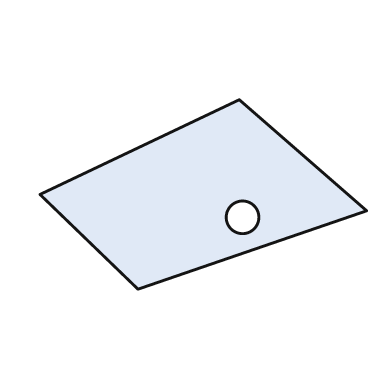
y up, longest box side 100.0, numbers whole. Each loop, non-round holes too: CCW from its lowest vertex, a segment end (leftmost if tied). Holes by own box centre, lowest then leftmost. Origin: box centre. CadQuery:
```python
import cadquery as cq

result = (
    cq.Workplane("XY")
    .moveTo(-20.0, -29.0)
    .lineTo(50.0, -5.0)
    .lineTo(11.0, 29.0)
    .lineTo(-50.0, 0.0)
    .close()
    .moveTo(12.0, -7.0)
    .circle(5.0)
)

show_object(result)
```